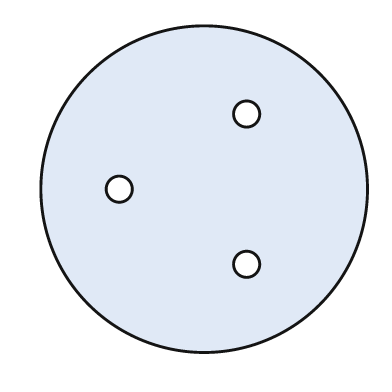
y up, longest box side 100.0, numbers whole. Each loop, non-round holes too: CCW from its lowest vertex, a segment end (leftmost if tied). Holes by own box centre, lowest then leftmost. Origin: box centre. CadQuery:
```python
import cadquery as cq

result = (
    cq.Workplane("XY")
    .moveTo(0.0, 0.0)
    .circle(50.0)
    .moveTo(13.0, -23.0)
    .circle(4.0)
    .moveTo(-26.0, 0.0)
    .circle(4.0)
    .moveTo(13.0, 23.0)
    .circle(4.0)
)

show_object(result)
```